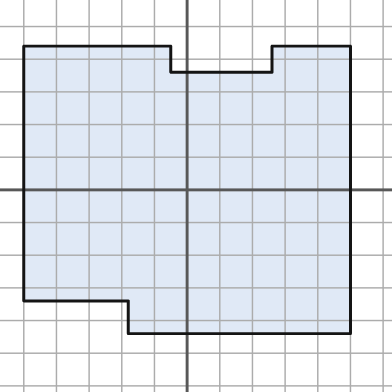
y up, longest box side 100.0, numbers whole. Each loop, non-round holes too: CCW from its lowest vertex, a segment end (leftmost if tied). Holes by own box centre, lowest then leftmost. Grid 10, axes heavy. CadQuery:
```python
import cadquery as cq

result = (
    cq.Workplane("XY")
    .moveTo(-18.0, -44.0)
    .lineTo(50.0, -44.0)
    .lineTo(50.0, 44.0)
    .lineTo(26.0, 44.0)
    .lineTo(26.0, 36.0)
    .lineTo(-5.0, 36.0)
    .lineTo(-5.0, 44.0)
    .lineTo(-50.0, 44.0)
    .lineTo(-50.0, -34.0)
    .lineTo(-18.0, -34.0)
    .close()
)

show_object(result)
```